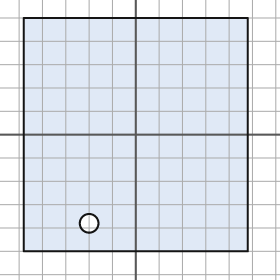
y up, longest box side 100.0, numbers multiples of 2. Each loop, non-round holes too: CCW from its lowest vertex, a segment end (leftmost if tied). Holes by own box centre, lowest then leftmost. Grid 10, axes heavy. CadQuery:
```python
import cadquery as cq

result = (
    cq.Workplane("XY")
    .moveTo(-48.0, -50.0)
    .lineTo(48.0, -50.0)
    .lineTo(48.0, 50.0)
    .lineTo(-48.0, 50.0)
    .close()
    .moveTo(-20.0, -38.0)
    .circle(4.0)
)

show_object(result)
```